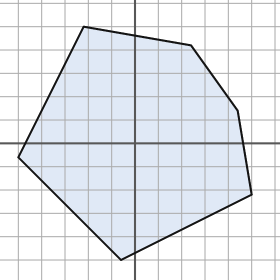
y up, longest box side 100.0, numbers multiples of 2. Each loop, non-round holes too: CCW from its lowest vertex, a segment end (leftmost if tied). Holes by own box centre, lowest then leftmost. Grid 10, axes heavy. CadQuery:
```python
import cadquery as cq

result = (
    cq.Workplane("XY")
    .moveTo(-6.0, -50.0)
    .lineTo(50.0, -22.0)
    .lineTo(44.0, 14.0)
    .lineTo(24.0, 42.0)
    .lineTo(-22.0, 50.0)
    .lineTo(-50.0, -6.0)
    .close()
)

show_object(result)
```